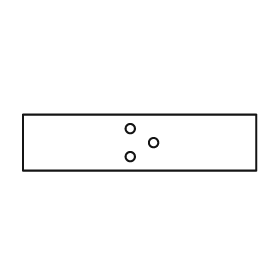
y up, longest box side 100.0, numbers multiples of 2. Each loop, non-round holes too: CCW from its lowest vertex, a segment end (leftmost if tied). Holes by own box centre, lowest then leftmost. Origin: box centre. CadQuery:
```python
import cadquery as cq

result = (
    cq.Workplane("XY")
    .moveTo(-50.0, -12.0)
    .lineTo(50.0, -12.0)
    .lineTo(50.0, 12.0)
    .lineTo(-50.0, 12.0)
    .close()
    .moveTo(-4.0, -6.0)
    .circle(2.0)
    .moveTo(6.0, 0.0)
    .circle(2.0)
    .moveTo(-4.0, 6.0)
    .circle(2.0)
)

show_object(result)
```